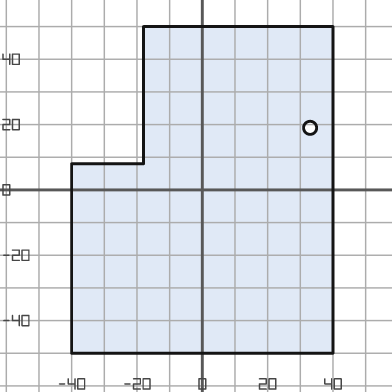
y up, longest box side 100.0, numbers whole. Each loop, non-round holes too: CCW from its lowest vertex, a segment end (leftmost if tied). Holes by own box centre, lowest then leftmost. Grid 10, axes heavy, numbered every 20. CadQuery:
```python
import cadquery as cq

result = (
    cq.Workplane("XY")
    .moveTo(-40.0, -50.0)
    .lineTo(40.0, -50.0)
    .lineTo(40.0, 50.0)
    .lineTo(-18.0, 50.0)
    .lineTo(-18.0, 8.0)
    .lineTo(-40.0, 8.0)
    .close()
    .moveTo(33.0, 19.0)
    .circle(2.0)
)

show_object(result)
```